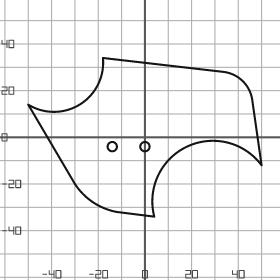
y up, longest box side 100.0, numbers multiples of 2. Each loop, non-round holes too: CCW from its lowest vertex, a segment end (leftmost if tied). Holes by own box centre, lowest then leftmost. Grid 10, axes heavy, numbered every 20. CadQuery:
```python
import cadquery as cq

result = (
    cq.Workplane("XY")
    .moveTo(4.0, -34.0)
    .threePointArc((18.0, -4.0), (50.0, -12.0))
    .lineTo(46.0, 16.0)
    .threePointArc((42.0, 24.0), (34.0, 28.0))
    .lineTo(-18.0, 34.0)
    .threePointArc((-28.0, 14.0), (-50.0, 14.0))
    .lineTo(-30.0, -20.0)
    .threePointArc((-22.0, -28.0), (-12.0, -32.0))
    .close()
    .moveTo(-14.0, -4.0)
    .circle(2.0)
    .moveTo(0.0, -4.0)
    .circle(2.0)
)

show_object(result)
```